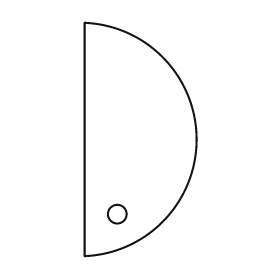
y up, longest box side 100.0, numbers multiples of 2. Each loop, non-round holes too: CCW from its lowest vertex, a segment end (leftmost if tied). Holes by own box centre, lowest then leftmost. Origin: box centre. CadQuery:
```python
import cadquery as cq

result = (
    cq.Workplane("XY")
    .moveTo(-24.0, -50.0)
    .threePointArc((24.0, 0.0), (-24.0, 50.0))
    .close()
    .moveTo(-10.0, -32.0)
    .circle(4.0)
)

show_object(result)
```